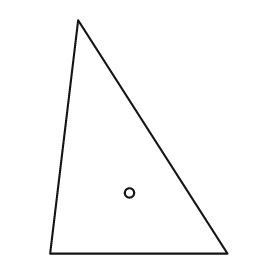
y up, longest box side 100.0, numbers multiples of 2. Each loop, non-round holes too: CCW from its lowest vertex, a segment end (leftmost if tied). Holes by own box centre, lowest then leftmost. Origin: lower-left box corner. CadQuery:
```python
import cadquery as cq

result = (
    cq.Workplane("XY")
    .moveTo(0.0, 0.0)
    .lineTo(76.0, 0.0)
    .lineTo(12.0, 100.0)
    .close()
    .moveTo(34.0, 26.0)
    .circle(2.0)
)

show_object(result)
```